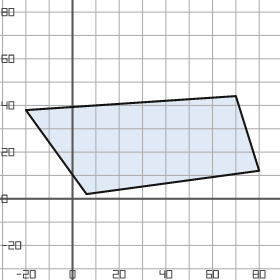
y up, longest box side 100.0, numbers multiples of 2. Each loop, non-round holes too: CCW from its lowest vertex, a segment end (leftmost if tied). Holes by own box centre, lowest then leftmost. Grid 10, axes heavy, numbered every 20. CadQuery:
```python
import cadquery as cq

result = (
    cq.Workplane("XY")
    .moveTo(6.0, 2.0)
    .lineTo(80.0, 12.0)
    .lineTo(70.0, 44.0)
    .lineTo(-20.0, 38.0)
    .close()
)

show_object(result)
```